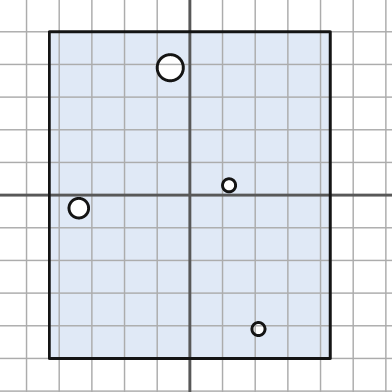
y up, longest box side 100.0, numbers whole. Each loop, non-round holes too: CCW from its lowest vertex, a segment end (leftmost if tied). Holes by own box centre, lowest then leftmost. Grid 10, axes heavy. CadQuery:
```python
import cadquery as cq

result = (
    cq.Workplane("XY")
    .moveTo(-43.0, -50.0)
    .lineTo(43.0, -50.0)
    .lineTo(43.0, 50.0)
    .lineTo(-43.0, 50.0)
    .close()
    .moveTo(21.0, -41.0)
    .circle(2.0)
    .moveTo(-34.0, -4.0)
    .circle(3.0)
    .moveTo(12.0, 3.0)
    .circle(2.0)
    .moveTo(-6.0, 39.0)
    .circle(4.0)
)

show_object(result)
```